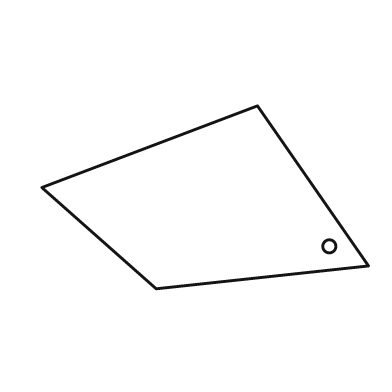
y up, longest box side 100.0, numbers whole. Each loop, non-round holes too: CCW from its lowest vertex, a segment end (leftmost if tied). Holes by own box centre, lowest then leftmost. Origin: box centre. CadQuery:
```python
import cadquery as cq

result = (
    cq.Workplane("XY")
    .moveTo(-15.0, -28.0)
    .lineTo(50.0, -21.0)
    .lineTo(16.0, 28.0)
    .lineTo(-50.0, 3.0)
    .close()
    .moveTo(38.0, -15.0)
    .circle(2.0)
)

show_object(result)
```